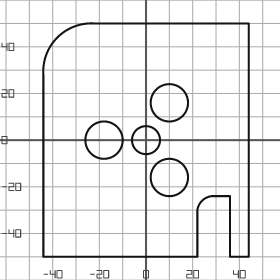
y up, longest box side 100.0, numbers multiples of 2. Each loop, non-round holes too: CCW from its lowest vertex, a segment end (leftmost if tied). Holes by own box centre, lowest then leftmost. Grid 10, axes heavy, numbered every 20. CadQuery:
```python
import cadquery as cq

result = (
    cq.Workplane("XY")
    .moveTo(-44.0, -50.0)
    .lineTo(22.0, -50.0)
    .lineTo(22.0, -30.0)
    .threePointArc((24.0, -26.0), (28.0, -24.0))
    .lineTo(36.0, -24.0)
    .lineTo(36.0, -50.0)
    .lineTo(44.0, -50.0)
    .lineTo(44.0, 50.0)
    .lineTo(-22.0, 50.0)
    .threePointArc((-38.0, 44.0), (-44.0, 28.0))
    .close()
    .moveTo(10.0, -16.0)
    .circle(8.0)
    .moveTo(-18.0, 0.0)
    .circle(8.0)
    .moveTo(0.0, 0.0)
    .circle(6.0)
    .moveTo(10.0, 16.0)
    .circle(8.0)
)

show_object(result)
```